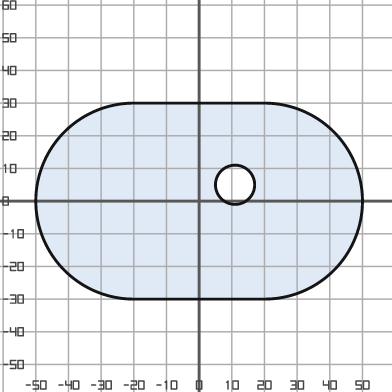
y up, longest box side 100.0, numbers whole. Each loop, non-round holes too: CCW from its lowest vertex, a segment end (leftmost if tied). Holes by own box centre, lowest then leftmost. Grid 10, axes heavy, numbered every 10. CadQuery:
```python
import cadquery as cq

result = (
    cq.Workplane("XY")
    .moveTo(-20.0, -30.0)
    .lineTo(20.0, -30.0)
    .threePointArc((50.0, 0.0), (20.0, 30.0))
    .lineTo(-20.0, 30.0)
    .threePointArc((-50.0, 0.0), (-20.0, -30.0))
    .close()
    .moveTo(11.0, 5.0)
    .circle(6.0)
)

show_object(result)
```